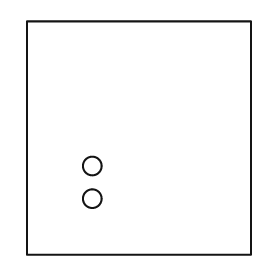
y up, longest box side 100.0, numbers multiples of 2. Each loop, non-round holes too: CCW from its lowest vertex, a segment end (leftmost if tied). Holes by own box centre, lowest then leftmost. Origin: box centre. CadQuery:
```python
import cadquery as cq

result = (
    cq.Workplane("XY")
    .moveTo(-48.0, -50.0)
    .lineTo(48.0, -50.0)
    .lineTo(48.0, 50.0)
    .lineTo(-48.0, 50.0)
    .close()
    .moveTo(-20.0, -26.0)
    .circle(4.0)
    .moveTo(-20.0, -12.0)
    .circle(4.0)
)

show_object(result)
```